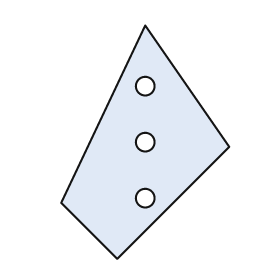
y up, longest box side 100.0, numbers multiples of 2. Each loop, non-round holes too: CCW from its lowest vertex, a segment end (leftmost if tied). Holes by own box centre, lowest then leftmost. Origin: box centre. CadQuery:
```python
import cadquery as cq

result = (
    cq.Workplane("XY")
    .moveTo(-12.0, -50.0)
    .lineTo(36.0, -2.0)
    .lineTo(0.0, 50.0)
    .lineTo(-36.0, -26.0)
    .close()
    .moveTo(0.0, -24.0)
    .circle(4.0)
    .moveTo(0.0, 0.0)
    .circle(4.0)
    .moveTo(0.0, 24.0)
    .circle(4.0)
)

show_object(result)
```